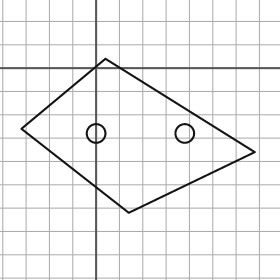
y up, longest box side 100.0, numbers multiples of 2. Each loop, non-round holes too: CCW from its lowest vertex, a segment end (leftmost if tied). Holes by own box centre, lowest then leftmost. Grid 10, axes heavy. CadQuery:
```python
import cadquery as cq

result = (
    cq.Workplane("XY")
    .moveTo(14.0, -62.0)
    .lineTo(68.0, -36.0)
    .lineTo(4.0, 4.0)
    .lineTo(-32.0, -26.0)
    .close()
    .moveTo(0.0, -28.0)
    .circle(4.0)
    .moveTo(38.0, -28.0)
    .circle(4.0)
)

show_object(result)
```